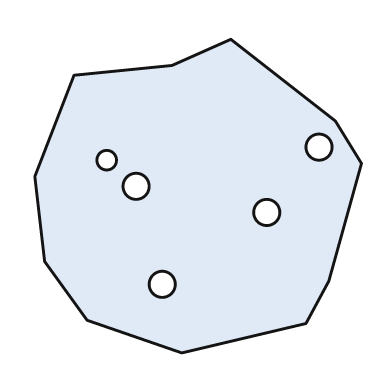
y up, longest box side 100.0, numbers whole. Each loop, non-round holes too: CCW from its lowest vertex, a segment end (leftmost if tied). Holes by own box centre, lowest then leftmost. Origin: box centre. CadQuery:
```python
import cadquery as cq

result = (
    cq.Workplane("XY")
    .moveTo(-5.0, -48.0)
    .lineTo(33.0, -39.0)
    .lineTo(40.0, -26.0)
    .lineTo(50.0, 10.0)
    .lineTo(42.0, 23.0)
    .lineTo(10.0, 48.0)
    .lineTo(-8.0, 40.0)
    .lineTo(-38.0, 37.0)
    .lineTo(-50.0, 6.0)
    .lineTo(-47.0, -20.0)
    .lineTo(-34.0, -38.0)
    .close()
    .moveTo(-11.0, -27.0)
    .circle(4.0)
    .moveTo(21.0, -5.0)
    .circle(4.0)
    .moveTo(-19.0, 3.0)
    .circle(4.0)
    .moveTo(-28.0, 11.0)
    .circle(3.0)
    .moveTo(37.0, 15.0)
    .circle(4.0)
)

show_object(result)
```